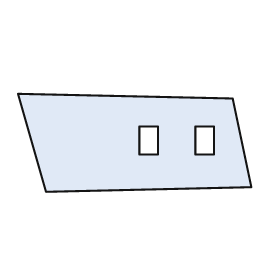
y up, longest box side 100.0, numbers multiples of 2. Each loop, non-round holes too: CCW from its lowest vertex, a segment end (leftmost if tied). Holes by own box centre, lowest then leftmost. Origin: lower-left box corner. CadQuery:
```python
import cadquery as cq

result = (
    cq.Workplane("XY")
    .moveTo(12.0, 0.0)
    .lineTo(100.0, 2.0)
    .lineTo(92.0, 40.0)
    .lineTo(0.0, 42.0)
    .close()
    .moveTo(52.0, 16.0)
    .lineTo(60.0, 16.0)
    .lineTo(60.0, 28.0)
    .lineTo(52.0, 28.0)
    .close()
    .moveTo(76.0, 16.0)
    .lineTo(84.0, 16.0)
    .lineTo(84.0, 28.0)
    .lineTo(76.0, 28.0)
    .close()
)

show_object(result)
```